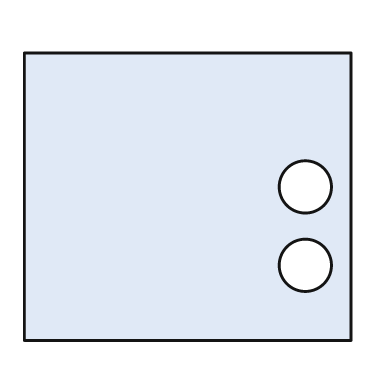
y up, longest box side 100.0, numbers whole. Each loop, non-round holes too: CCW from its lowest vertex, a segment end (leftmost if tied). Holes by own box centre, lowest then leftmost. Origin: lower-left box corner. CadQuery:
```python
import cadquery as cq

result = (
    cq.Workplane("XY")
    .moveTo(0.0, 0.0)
    .lineTo(100.0, 0.0)
    .lineTo(100.0, 88.0)
    .lineTo(0.0, 88.0)
    .close()
    .moveTo(86.0, 23.0)
    .circle(8.0)
    .moveTo(86.0, 47.0)
    .circle(8.0)
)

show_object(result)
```